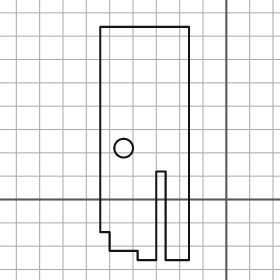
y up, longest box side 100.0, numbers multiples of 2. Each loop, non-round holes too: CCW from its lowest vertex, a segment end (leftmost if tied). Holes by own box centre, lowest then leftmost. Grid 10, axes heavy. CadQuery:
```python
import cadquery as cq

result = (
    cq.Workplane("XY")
    .moveTo(-38.0, -26.0)
    .lineTo(-30.0, -26.0)
    .lineTo(-30.0, 12.0)
    .lineTo(-26.0, 12.0)
    .lineTo(-26.0, -26.0)
    .lineTo(-16.0, -26.0)
    .lineTo(-16.0, 74.0)
    .lineTo(-54.0, 74.0)
    .lineTo(-54.0, -14.0)
    .lineTo(-50.0, -14.0)
    .lineTo(-50.0, -22.0)
    .lineTo(-38.0, -22.0)
    .close()
    .moveTo(-44.0, 22.0)
    .circle(4.0)
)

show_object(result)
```